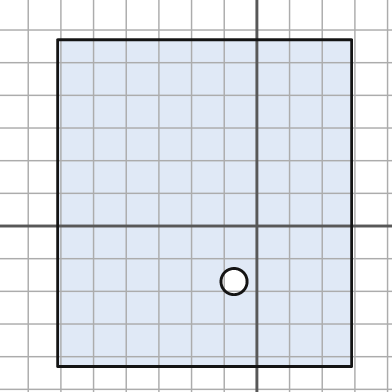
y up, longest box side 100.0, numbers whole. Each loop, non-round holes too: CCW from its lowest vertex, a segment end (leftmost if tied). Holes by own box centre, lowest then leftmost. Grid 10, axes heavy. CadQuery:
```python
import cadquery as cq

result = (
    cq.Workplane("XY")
    .moveTo(-61.0, -43.0)
    .lineTo(29.0, -43.0)
    .lineTo(29.0, 57.0)
    .lineTo(-61.0, 57.0)
    .close()
    .moveTo(-7.0, -17.0)
    .circle(4.0)
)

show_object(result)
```